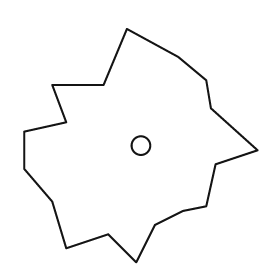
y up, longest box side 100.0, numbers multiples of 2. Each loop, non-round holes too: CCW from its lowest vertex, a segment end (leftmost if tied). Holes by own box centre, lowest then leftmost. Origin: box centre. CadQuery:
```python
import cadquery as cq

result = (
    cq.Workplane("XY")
    .moveTo(-2.0, -50.0)
    .lineTo(6.0, -34.0)
    .lineTo(18.0, -28.0)
    .lineTo(28.0, -26.0)
    .lineTo(32.0, -8.0)
    .lineTo(50.0, -2.0)
    .lineTo(30.0, 16.0)
    .lineTo(28.0, 28.0)
    .lineTo(16.0, 38.0)
    .lineTo(-6.0, 50.0)
    .lineTo(-16.0, 26.0)
    .lineTo(-38.0, 26.0)
    .lineTo(-32.0, 10.0)
    .lineTo(-50.0, 6.0)
    .lineTo(-50.0, -10.0)
    .lineTo(-38.0, -24.0)
    .lineTo(-32.0, -44.0)
    .lineTo(-14.0, -38.0)
    .close()
    .moveTo(0.0, 0.0)
    .circle(4.0)
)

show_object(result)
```